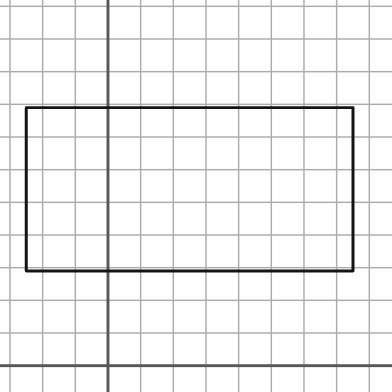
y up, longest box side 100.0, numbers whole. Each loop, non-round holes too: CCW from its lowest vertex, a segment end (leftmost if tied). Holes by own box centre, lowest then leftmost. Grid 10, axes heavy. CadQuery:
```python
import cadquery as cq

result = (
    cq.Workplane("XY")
    .moveTo(-25.0, 29.0)
    .lineTo(75.0, 29.0)
    .lineTo(75.0, 79.0)
    .lineTo(-25.0, 79.0)
    .close()
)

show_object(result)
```